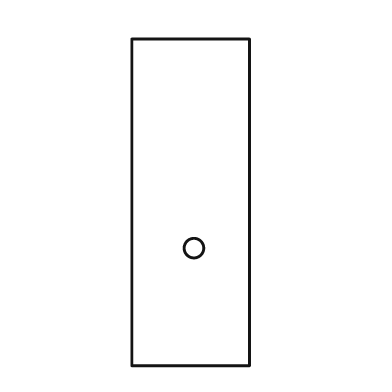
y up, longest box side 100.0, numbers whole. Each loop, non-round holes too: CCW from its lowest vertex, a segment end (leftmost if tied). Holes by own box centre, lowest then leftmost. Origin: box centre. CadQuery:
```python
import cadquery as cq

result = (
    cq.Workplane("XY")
    .moveTo(-18.0, -50.0)
    .lineTo(18.0, -50.0)
    .lineTo(18.0, 50.0)
    .lineTo(-18.0, 50.0)
    .close()
    .moveTo(1.0, -14.0)
    .circle(3.0)
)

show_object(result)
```